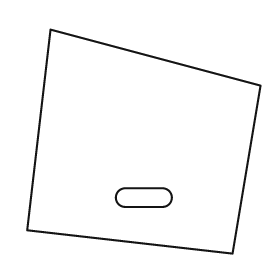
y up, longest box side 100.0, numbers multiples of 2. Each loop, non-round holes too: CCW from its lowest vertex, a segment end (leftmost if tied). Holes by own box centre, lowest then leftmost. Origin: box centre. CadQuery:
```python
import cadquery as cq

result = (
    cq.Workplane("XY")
    .moveTo(38.0, -48.0)
    .lineTo(50.0, 24.0)
    .lineTo(-40.0, 48.0)
    .lineTo(-50.0, -38.0)
    .close()
    .moveTo(-8.0, -28.0)
    .lineTo(8.0, -28.0)
    .threePointArc((12.0, -24.0), (8.0, -20.0))
    .lineTo(-8.0, -20.0)
    .threePointArc((-12.0, -24.0), (-8.0, -28.0))
    .close()
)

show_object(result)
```